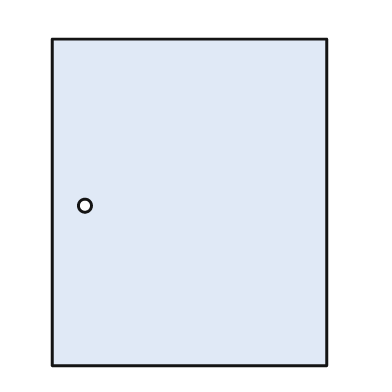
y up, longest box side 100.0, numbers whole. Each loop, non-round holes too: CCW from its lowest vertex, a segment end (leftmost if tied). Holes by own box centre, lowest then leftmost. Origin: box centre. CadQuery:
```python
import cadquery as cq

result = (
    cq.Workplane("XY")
    .moveTo(-42.0, -50.0)
    .lineTo(42.0, -50.0)
    .lineTo(42.0, 50.0)
    .lineTo(-42.0, 50.0)
    .close()
    .moveTo(-32.0, -1.0)
    .circle(2.0)
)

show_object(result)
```